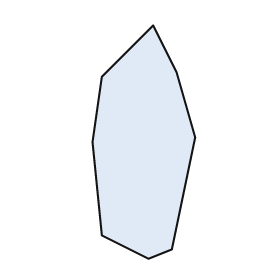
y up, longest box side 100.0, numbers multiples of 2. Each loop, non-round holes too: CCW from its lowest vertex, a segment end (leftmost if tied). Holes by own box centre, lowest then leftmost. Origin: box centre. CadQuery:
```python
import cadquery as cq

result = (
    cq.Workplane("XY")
    .moveTo(2.0, -50.0)
    .lineTo(12.0, -46.0)
    .lineTo(22.0, 2.0)
    .lineTo(14.0, 30.0)
    .lineTo(4.0, 50.0)
    .lineTo(-18.0, 28.0)
    .lineTo(-22.0, 0.0)
    .lineTo(-18.0, -40.0)
    .close()
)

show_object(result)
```